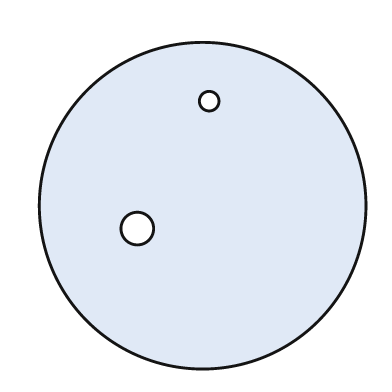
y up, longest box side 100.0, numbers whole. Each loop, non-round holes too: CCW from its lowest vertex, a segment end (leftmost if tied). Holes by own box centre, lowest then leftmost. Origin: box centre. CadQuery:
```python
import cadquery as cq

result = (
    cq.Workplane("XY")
    .moveTo(0.0, 0.0)
    .circle(50.0)
    .moveTo(-20.0, -7.0)
    .circle(5.0)
    .moveTo(2.0, 32.0)
    .circle(3.0)
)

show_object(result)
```